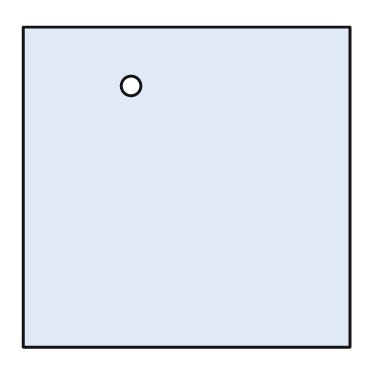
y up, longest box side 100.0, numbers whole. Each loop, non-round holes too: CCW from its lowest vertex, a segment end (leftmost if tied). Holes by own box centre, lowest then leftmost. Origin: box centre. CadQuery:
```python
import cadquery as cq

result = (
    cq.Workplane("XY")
    .moveTo(-50.0, -49.0)
    .lineTo(50.0, -49.0)
    .lineTo(50.0, 49.0)
    .lineTo(-50.0, 49.0)
    .close()
    .moveTo(-17.0, 31.0)
    .circle(3.0)
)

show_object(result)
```